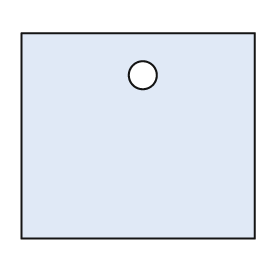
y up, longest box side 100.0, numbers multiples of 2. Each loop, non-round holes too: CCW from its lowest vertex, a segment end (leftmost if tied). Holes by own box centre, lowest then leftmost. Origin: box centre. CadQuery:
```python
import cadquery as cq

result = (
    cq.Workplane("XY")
    .moveTo(-50.0, -44.0)
    .lineTo(50.0, -44.0)
    .lineTo(50.0, 44.0)
    .lineTo(-50.0, 44.0)
    .close()
    .moveTo(2.0, 26.0)
    .circle(6.0)
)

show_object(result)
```